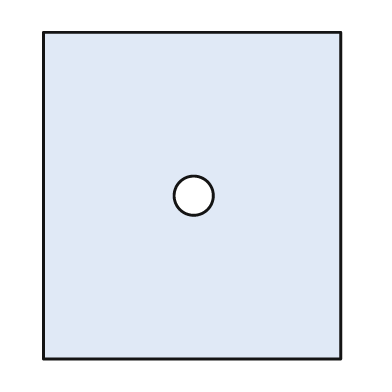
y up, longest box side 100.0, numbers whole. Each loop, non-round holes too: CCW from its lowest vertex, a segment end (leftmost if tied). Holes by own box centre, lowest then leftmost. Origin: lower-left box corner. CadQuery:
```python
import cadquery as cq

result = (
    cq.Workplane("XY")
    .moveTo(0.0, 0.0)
    .lineTo(91.0, 0.0)
    .lineTo(91.0, 100.0)
    .lineTo(0.0, 100.0)
    .close()
    .moveTo(46.0, 50.0)
    .circle(6.0)
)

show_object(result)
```